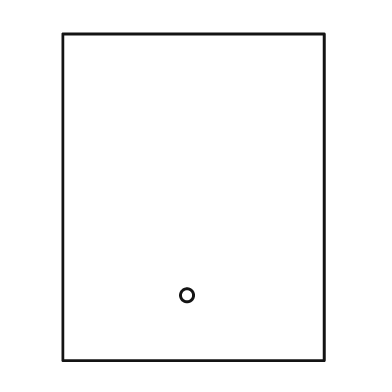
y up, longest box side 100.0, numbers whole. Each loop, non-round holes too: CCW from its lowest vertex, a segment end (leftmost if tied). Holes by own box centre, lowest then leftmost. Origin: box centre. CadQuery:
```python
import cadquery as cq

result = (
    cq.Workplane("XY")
    .moveTo(-40.0, -50.0)
    .lineTo(40.0, -50.0)
    .lineTo(40.0, 50.0)
    .lineTo(-40.0, 50.0)
    .close()
    .moveTo(-2.0, -30.0)
    .circle(2.0)
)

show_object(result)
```